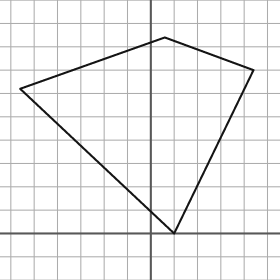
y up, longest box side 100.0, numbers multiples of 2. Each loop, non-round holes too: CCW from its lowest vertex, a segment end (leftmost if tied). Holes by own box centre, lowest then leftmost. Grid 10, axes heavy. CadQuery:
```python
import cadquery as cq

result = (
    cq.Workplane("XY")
    .moveTo(10.0, 0.0)
    .lineTo(44.0, 70.0)
    .lineTo(6.0, 84.0)
    .lineTo(-56.0, 62.0)
    .close()
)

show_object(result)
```